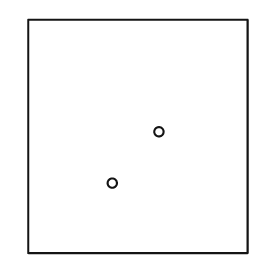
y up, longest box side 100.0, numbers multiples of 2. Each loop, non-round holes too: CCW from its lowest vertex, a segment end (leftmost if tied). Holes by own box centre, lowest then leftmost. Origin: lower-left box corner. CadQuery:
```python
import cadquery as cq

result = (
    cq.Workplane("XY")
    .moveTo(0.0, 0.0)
    .lineTo(94.0, 0.0)
    .lineTo(94.0, 100.0)
    .lineTo(0.0, 100.0)
    .close()
    .moveTo(36.0, 30.0)
    .circle(2.0)
    .moveTo(56.0, 52.0)
    .circle(2.0)
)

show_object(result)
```